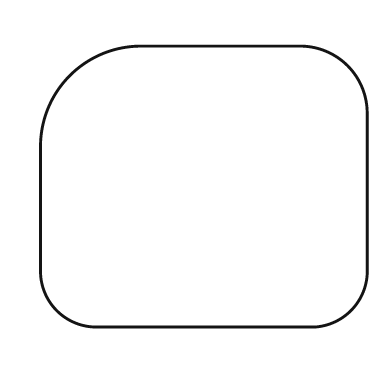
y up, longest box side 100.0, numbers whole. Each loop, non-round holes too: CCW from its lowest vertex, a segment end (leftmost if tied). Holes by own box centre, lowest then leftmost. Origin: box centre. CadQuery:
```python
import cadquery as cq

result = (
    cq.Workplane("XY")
    .moveTo(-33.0, -43.0)
    .lineTo(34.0, -43.0)
    .threePointArc((45.0, -38.0), (50.0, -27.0))
    .lineTo(50.0, 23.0)
    .threePointArc((44.0, 37.0), (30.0, 43.0))
    .lineTo(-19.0, 43.0)
    .threePointArc((-41.0, 34.0), (-50.0, 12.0))
    .lineTo(-50.0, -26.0)
    .threePointArc((-45.0, -38.0), (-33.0, -43.0))
    .close()
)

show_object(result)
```